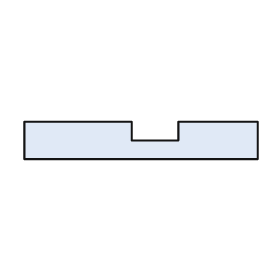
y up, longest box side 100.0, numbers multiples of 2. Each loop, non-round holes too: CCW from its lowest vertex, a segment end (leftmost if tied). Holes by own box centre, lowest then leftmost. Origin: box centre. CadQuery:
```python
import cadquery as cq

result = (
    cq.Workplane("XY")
    .moveTo(-50.0, -8.0)
    .lineTo(50.0, -8.0)
    .lineTo(50.0, 8.0)
    .lineTo(16.0, 8.0)
    .lineTo(16.0, 0.0)
    .lineTo(-4.0, 0.0)
    .lineTo(-4.0, 8.0)
    .lineTo(-50.0, 8.0)
    .close()
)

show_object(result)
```